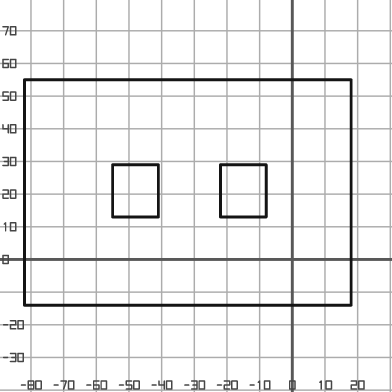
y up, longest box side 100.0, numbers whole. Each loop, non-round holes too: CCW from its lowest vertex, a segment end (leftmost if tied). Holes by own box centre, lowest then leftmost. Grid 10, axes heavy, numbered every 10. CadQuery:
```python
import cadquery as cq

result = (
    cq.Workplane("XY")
    .moveTo(-82.0, -14.0)
    .lineTo(18.0, -14.0)
    .lineTo(18.0, 55.0)
    .lineTo(-82.0, 55.0)
    .close()
    .moveTo(-55.0, 13.0)
    .lineTo(-41.0, 13.0)
    .lineTo(-41.0, 29.0)
    .lineTo(-55.0, 29.0)
    .close()
    .moveTo(-22.0, 13.0)
    .lineTo(-8.0, 13.0)
    .lineTo(-8.0, 29.0)
    .lineTo(-22.0, 29.0)
    .close()
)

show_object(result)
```